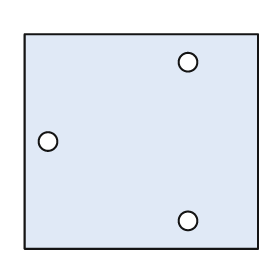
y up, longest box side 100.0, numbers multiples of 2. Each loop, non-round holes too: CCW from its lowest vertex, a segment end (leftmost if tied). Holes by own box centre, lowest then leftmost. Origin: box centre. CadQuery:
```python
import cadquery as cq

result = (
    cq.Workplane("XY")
    .moveTo(-50.0, -46.0)
    .lineTo(50.0, -46.0)
    .lineTo(50.0, 46.0)
    .lineTo(-50.0, 46.0)
    .close()
    .moveTo(20.0, -34.0)
    .circle(4.0)
    .moveTo(-40.0, 0.0)
    .circle(4.0)
    .moveTo(20.0, 34.0)
    .circle(4.0)
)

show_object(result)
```